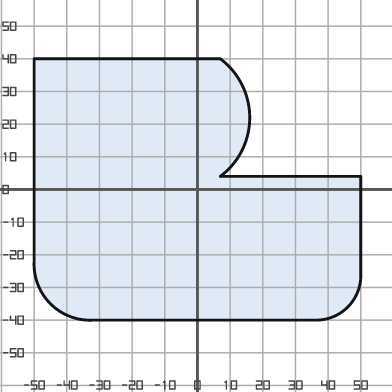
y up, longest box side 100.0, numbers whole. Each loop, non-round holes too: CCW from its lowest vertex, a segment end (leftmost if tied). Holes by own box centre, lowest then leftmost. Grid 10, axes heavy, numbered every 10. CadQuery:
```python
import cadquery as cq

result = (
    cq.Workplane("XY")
    .moveTo(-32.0, -40.0)
    .lineTo(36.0, -40.0)
    .threePointArc((46.0, -36.0), (50.0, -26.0))
    .lineTo(50.0, 4.0)
    .lineTo(7.0, 4.0)
    .threePointArc((16.0, 22.0), (7.0, 40.0))
    .lineTo(-50.0, 40.0)
    .lineTo(-50.0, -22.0)
    .threePointArc((-45.0, -35.0), (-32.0, -40.0))
    .close()
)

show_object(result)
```